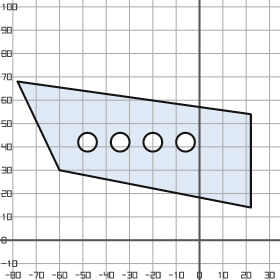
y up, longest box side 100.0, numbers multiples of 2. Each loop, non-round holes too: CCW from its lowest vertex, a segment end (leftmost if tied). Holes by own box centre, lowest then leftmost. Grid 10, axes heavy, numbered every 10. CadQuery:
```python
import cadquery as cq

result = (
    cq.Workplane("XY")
    .moveTo(22.0, 14.0)
    .lineTo(22.0, 54.0)
    .lineTo(-78.0, 68.0)
    .lineTo(-60.0, 30.0)
    .close()
    .moveTo(-48.0, 42.0)
    .circle(4.0)
    .moveTo(-34.0, 42.0)
    .circle(4.0)
    .moveTo(-20.0, 42.0)
    .circle(4.0)
    .moveTo(-6.0, 42.0)
    .circle(4.0)
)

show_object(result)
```